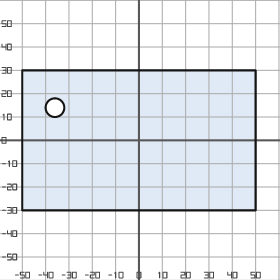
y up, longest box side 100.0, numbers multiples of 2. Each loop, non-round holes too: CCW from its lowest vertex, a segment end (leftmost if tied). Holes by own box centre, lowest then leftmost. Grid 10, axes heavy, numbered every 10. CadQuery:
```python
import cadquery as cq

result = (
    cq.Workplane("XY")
    .moveTo(-50.0, -30.0)
    .lineTo(50.0, -30.0)
    .lineTo(50.0, 30.0)
    .lineTo(-50.0, 30.0)
    .close()
    .moveTo(-36.0, 14.0)
    .circle(4.0)
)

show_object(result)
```